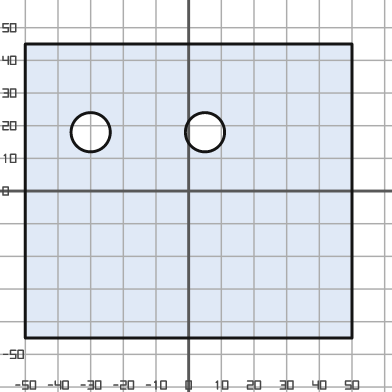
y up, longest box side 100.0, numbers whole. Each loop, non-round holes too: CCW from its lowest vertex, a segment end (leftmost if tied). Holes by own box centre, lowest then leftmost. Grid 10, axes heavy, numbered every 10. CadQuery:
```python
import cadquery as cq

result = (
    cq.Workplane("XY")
    .moveTo(-50.0, -45.0)
    .lineTo(50.0, -45.0)
    .lineTo(50.0, 45.0)
    .lineTo(-50.0, 45.0)
    .close()
    .moveTo(-30.0, 18.0)
    .circle(6.0)
    .moveTo(5.0, 18.0)
    .circle(6.0)
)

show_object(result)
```